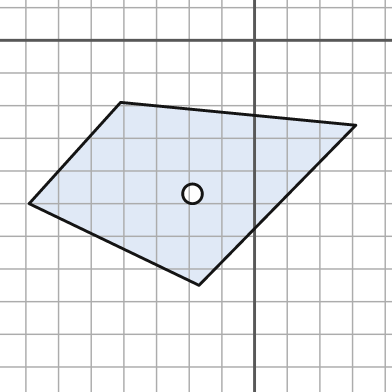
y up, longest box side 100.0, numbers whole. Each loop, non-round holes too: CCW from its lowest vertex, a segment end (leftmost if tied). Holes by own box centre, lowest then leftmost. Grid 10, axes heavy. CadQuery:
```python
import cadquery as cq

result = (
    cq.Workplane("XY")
    .moveTo(-17.0, -75.0)
    .lineTo(31.0, -26.0)
    .lineTo(-41.0, -19.0)
    .lineTo(-69.0, -50.0)
    .close()
    .moveTo(-19.0, -47.0)
    .circle(3.0)
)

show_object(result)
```